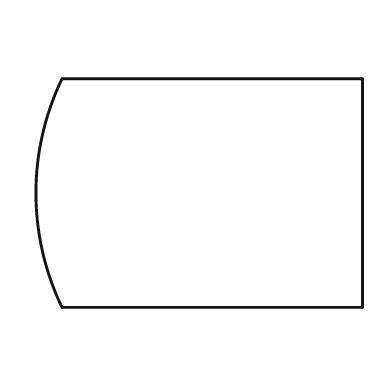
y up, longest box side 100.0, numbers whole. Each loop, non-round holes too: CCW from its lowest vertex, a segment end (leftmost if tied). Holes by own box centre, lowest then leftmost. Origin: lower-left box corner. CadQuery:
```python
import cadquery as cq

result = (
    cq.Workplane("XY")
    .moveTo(8.0, 0.0)
    .lineTo(100.0, 0.0)
    .lineTo(100.0, 70.0)
    .lineTo(8.0, 70.0)
    .threePointArc((0.0, 35.0), (8.0, 0.0))
    .close()
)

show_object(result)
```